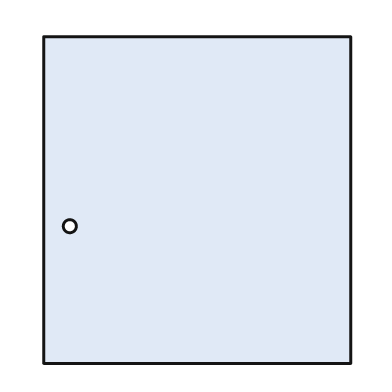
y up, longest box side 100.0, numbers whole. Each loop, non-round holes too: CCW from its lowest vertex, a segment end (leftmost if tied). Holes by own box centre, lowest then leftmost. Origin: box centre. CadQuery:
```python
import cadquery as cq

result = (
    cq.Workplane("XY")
    .moveTo(-47.0, -50.0)
    .lineTo(47.0, -50.0)
    .lineTo(47.0, 50.0)
    .lineTo(-47.0, 50.0)
    .close()
    .moveTo(-39.0, -8.0)
    .circle(2.0)
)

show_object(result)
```